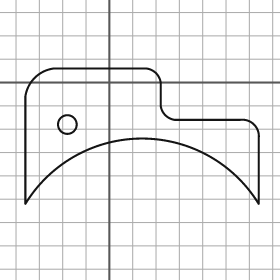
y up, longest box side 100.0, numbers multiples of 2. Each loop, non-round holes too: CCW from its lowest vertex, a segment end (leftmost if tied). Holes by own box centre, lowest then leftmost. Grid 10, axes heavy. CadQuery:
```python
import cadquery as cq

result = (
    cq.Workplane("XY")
    .moveTo(-36.0, -52.0)
    .threePointArc((14.0, -24.0), (64.0, -52.0))
    .lineTo(64.0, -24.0)
    .threePointArc((62.0, -18.0), (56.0, -16.0))
    .lineTo(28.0, -16.0)
    .threePointArc((24.0, -14.0), (22.0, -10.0))
    .lineTo(22.0, 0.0)
    .threePointArc((20.0, 4.0), (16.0, 6.0))
    .lineTo(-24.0, 6.0)
    .threePointArc((-32.0, 2.0), (-36.0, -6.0))
    .close()
    .moveTo(-18.0, -18.0)
    .circle(4.0)
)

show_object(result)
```